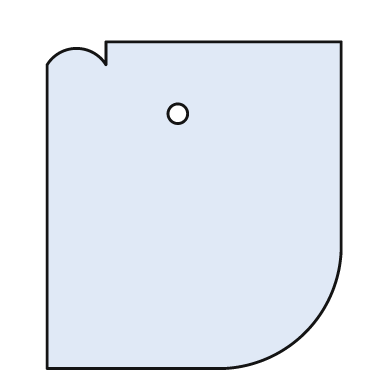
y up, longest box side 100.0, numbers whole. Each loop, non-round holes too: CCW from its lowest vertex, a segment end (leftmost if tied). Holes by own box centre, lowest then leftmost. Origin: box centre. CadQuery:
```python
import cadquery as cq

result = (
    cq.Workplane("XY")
    .moveTo(-45.0, -50.0)
    .lineTo(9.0, -50.0)
    .threePointArc((34.0, -39.0), (45.0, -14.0))
    .lineTo(45.0, 50.0)
    .lineTo(-27.0, 50.0)
    .lineTo(-27.0, 43.0)
    .threePointArc((-36.0, 48.0), (-45.0, 43.0))
    .close()
    .moveTo(-5.0, 28.0)
    .circle(3.0)
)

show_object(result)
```